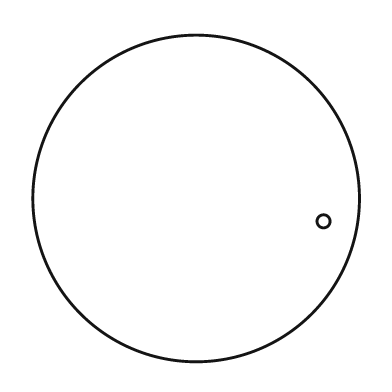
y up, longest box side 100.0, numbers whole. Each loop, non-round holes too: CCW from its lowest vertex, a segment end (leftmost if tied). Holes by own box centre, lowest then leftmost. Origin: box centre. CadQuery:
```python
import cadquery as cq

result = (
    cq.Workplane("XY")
    .moveTo(0.0, 0.0)
    .circle(50.0)
    .moveTo(39.0, -7.0)
    .circle(2.0)
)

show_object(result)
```